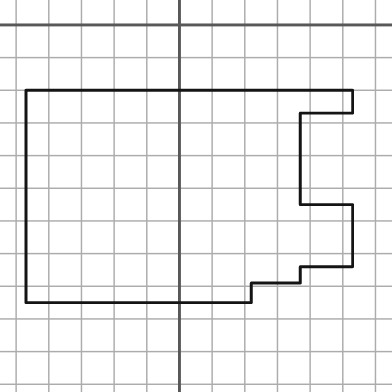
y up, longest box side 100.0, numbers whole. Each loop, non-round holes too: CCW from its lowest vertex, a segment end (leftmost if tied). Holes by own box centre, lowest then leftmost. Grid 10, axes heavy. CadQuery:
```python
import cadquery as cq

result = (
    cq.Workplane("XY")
    .moveTo(-47.0, -85.0)
    .lineTo(22.0, -85.0)
    .lineTo(22.0, -79.0)
    .lineTo(37.0, -79.0)
    .lineTo(37.0, -74.0)
    .lineTo(53.0, -74.0)
    .lineTo(53.0, -55.0)
    .lineTo(37.0, -55.0)
    .lineTo(37.0, -27.0)
    .lineTo(53.0, -27.0)
    .lineTo(53.0, -20.0)
    .lineTo(-47.0, -20.0)
    .close()
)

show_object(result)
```